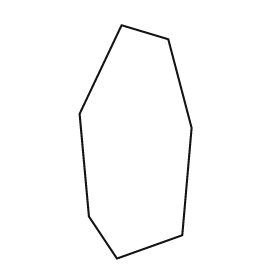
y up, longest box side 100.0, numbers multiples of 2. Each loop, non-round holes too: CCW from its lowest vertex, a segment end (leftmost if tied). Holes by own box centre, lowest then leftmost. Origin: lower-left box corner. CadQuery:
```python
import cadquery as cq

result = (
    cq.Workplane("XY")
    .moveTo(16.0, 0.0)
    .lineTo(44.0, 10.0)
    .lineTo(48.0, 56.0)
    .lineTo(38.0, 94.0)
    .lineTo(18.0, 100.0)
    .lineTo(0.0, 62.0)
    .lineTo(4.0, 18.0)
    .close()
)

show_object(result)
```